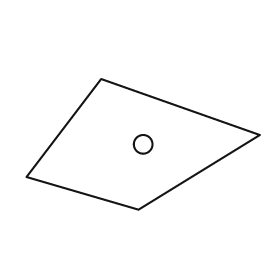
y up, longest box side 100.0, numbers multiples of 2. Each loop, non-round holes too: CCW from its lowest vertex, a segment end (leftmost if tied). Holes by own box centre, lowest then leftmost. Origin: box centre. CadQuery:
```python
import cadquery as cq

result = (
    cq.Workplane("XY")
    .moveTo(-2.0, -28.0)
    .lineTo(50.0, 4.0)
    .lineTo(-18.0, 28.0)
    .lineTo(-50.0, -14.0)
    .close()
    .moveTo(0.0, 0.0)
    .circle(4.0)
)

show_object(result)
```